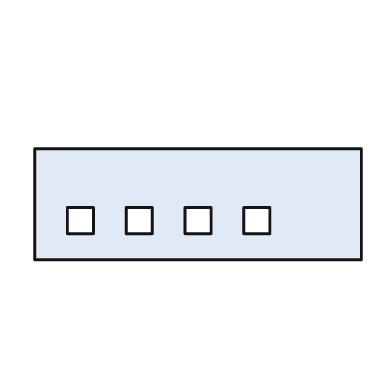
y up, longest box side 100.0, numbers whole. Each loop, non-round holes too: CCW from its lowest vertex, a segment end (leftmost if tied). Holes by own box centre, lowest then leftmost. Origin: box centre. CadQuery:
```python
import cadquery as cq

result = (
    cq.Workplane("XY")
    .moveTo(-50.0, -17.0)
    .lineTo(50.0, -17.0)
    .lineTo(50.0, 17.0)
    .lineTo(-50.0, 17.0)
    .close()
    .moveTo(-40.0, -9.0)
    .lineTo(-32.0, -9.0)
    .lineTo(-32.0, -1.0)
    .lineTo(-40.0, -1.0)
    .close()
    .moveTo(-22.0, -9.0)
    .lineTo(-14.0, -9.0)
    .lineTo(-14.0, -1.0)
    .lineTo(-22.0, -1.0)
    .close()
    .moveTo(-4.0, -9.0)
    .lineTo(4.0, -9.0)
    .lineTo(4.0, -1.0)
    .lineTo(-4.0, -1.0)
    .close()
    .moveTo(14.0, -9.0)
    .lineTo(22.0, -9.0)
    .lineTo(22.0, -1.0)
    .lineTo(14.0, -1.0)
    .close()
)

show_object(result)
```